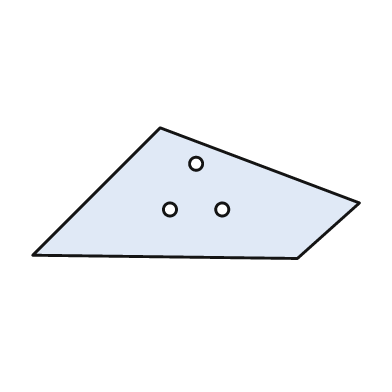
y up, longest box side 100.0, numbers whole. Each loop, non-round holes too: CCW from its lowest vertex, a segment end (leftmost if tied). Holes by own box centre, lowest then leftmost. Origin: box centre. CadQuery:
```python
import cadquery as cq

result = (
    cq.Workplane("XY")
    .moveTo(31.0, -20.0)
    .lineTo(50.0, -3.0)
    .lineTo(-11.0, 20.0)
    .lineTo(-50.0, -19.0)
    .close()
    .moveTo(-8.0, -5.0)
    .circle(2.0)
    .moveTo(8.0, -5.0)
    .circle(2.0)
    .moveTo(0.0, 9.0)
    .circle(2.0)
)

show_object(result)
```